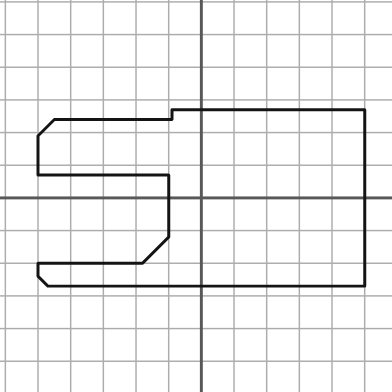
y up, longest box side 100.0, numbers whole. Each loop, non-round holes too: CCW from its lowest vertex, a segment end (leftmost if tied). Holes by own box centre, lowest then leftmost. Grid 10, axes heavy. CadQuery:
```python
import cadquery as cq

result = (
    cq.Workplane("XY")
    .moveTo(-47.0, -27.0)
    .lineTo(50.0, -27.0)
    .lineTo(50.0, 27.0)
    .lineTo(-9.0, 27.0)
    .lineTo(-9.0, 24.0)
    .lineTo(-45.0, 24.0)
    .lineTo(-50.0, 19.0)
    .lineTo(-50.0, 7.0)
    .lineTo(-10.0, 7.0)
    .lineTo(-10.0, -12.0)
    .lineTo(-18.0, -20.0)
    .lineTo(-50.0, -20.0)
    .lineTo(-50.0, -24.0)
    .close()
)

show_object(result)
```